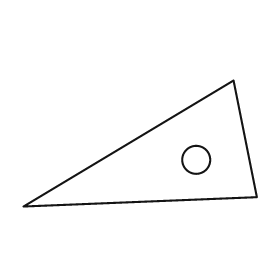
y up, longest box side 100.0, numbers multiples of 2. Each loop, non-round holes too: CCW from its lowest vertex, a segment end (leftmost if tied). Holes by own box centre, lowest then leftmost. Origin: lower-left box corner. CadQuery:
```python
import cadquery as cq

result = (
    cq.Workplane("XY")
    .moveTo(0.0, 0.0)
    .lineTo(100.0, 4.0)
    .lineTo(90.0, 54.0)
    .close()
    .moveTo(74.0, 20.0)
    .circle(6.0)
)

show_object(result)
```